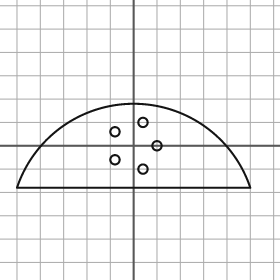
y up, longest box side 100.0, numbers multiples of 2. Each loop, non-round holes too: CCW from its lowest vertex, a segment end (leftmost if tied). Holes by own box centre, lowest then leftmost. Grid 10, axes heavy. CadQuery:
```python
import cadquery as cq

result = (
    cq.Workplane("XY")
    .moveTo(-50.0, -18.0)
    .lineTo(50.0, -18.0)
    .threePointArc((0.0, 18.0), (-50.0, -18.0))
    .close()
    .moveTo(4.0, -10.0)
    .circle(2.0)
    .moveTo(-8.0, -6.0)
    .circle(2.0)
    .moveTo(10.0, 0.0)
    .circle(2.0)
    .moveTo(-8.0, 6.0)
    .circle(2.0)
    .moveTo(4.0, 10.0)
    .circle(2.0)
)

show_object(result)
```